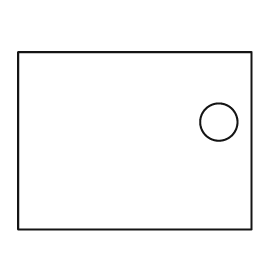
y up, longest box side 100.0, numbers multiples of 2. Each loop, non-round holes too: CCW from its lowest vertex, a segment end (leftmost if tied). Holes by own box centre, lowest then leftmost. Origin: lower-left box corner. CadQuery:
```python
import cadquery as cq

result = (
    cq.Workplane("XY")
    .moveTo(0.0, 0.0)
    .lineTo(100.0, 0.0)
    .lineTo(100.0, 76.0)
    .lineTo(0.0, 76.0)
    .close()
    .moveTo(86.0, 46.0)
    .circle(8.0)
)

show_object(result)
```